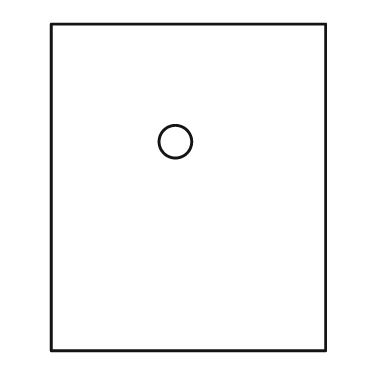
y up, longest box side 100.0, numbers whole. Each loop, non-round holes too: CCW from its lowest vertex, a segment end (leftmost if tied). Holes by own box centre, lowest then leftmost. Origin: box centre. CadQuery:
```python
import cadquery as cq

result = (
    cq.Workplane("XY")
    .moveTo(-42.0, -50.0)
    .lineTo(42.0, -50.0)
    .lineTo(42.0, 50.0)
    .lineTo(-42.0, 50.0)
    .close()
    .moveTo(-4.0, 14.0)
    .circle(5.0)
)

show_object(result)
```